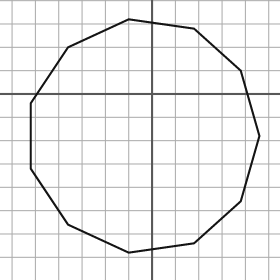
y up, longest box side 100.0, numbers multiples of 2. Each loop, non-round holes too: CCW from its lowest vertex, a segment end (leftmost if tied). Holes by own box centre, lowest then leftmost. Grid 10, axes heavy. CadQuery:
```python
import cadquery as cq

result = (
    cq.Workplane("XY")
    .moveTo(-10.0, -68.0)
    .lineTo(18.0, -64.0)
    .lineTo(38.0, -46.0)
    .lineTo(46.0, -18.0)
    .lineTo(38.0, 10.0)
    .lineTo(18.0, 28.0)
    .lineTo(-10.0, 32.0)
    .lineTo(-36.0, 20.0)
    .lineTo(-52.0, -4.0)
    .lineTo(-52.0, -32.0)
    .lineTo(-36.0, -56.0)
    .close()
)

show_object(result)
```